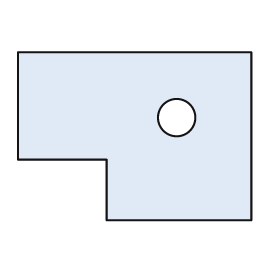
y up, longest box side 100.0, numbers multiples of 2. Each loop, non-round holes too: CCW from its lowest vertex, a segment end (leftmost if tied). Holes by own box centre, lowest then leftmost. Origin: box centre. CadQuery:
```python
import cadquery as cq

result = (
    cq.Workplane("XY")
    .moveTo(-12.0, -36.0)
    .lineTo(50.0, -36.0)
    .lineTo(50.0, 36.0)
    .lineTo(-50.0, 36.0)
    .lineTo(-50.0, -10.0)
    .lineTo(-12.0, -10.0)
    .close()
    .moveTo(18.0, 8.0)
    .circle(8.0)
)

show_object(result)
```